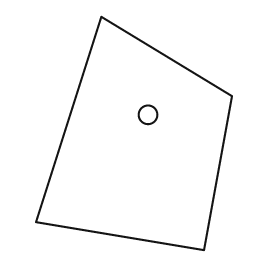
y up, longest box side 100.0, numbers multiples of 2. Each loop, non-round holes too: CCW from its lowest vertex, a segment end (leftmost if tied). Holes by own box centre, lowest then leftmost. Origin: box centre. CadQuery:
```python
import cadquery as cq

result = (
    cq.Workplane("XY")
    .moveTo(30.0, -50.0)
    .lineTo(42.0, 16.0)
    .lineTo(-14.0, 50.0)
    .lineTo(-42.0, -38.0)
    .close()
    .moveTo(6.0, 8.0)
    .circle(4.0)
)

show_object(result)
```